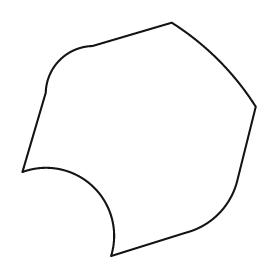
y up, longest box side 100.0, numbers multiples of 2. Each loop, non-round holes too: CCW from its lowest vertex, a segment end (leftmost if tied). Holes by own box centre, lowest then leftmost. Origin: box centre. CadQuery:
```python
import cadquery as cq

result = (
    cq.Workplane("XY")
    .moveTo(-12.0, -50.0)
    .lineTo(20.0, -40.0)
    .threePointArc((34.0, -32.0), (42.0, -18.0))
    .lineTo(50.0, 14.0)
    .threePointArc((34.0, 34.0), (14.0, 50.0))
    .lineTo(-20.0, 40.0)
    .threePointArc((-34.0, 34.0), (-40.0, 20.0))
    .lineTo(-50.0, -14.0)
    .threePointArc((-20.0, -20.0), (-12.0, -50.0))
    .close()
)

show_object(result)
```